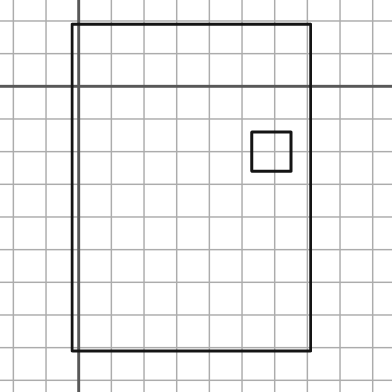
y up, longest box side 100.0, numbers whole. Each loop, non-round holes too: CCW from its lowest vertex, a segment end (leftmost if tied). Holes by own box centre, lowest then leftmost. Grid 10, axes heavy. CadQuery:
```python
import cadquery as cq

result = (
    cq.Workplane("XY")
    .moveTo(-2.0, -81.0)
    .lineTo(71.0, -81.0)
    .lineTo(71.0, 19.0)
    .lineTo(-2.0, 19.0)
    .close()
    .moveTo(53.0, -26.0)
    .lineTo(65.0, -26.0)
    .lineTo(65.0, -14.0)
    .lineTo(53.0, -14.0)
    .close()
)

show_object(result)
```